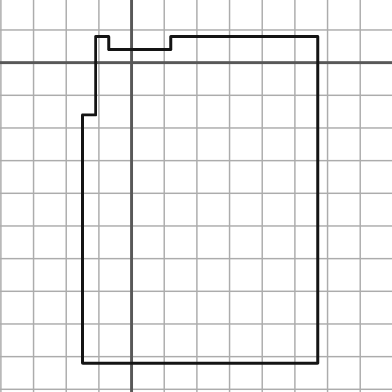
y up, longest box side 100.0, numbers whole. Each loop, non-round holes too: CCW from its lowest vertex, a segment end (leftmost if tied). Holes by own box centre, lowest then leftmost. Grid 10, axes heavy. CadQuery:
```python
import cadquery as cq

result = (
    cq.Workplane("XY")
    .moveTo(-15.0, -92.0)
    .lineTo(57.0, -92.0)
    .lineTo(57.0, 8.0)
    .lineTo(12.0, 8.0)
    .lineTo(12.0, 4.0)
    .lineTo(-7.0, 4.0)
    .lineTo(-7.0, 8.0)
    .lineTo(-11.0, 8.0)
    .lineTo(-11.0, -16.0)
    .lineTo(-15.0, -16.0)
    .close()
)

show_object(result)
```